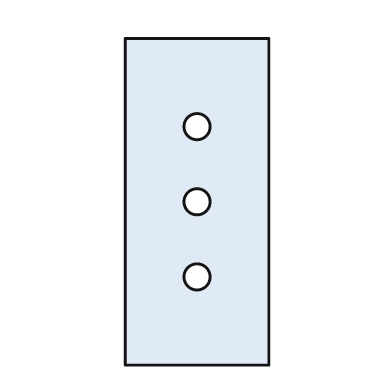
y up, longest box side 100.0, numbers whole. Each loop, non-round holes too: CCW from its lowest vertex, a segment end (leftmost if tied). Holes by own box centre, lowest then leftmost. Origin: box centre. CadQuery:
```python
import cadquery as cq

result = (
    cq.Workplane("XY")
    .moveTo(-22.0, -50.0)
    .lineTo(22.0, -50.0)
    .lineTo(22.0, 50.0)
    .lineTo(-22.0, 50.0)
    .close()
    .moveTo(0.0, -23.0)
    .circle(4.0)
    .moveTo(0.0, 0.0)
    .circle(4.0)
    .moveTo(0.0, 23.0)
    .circle(4.0)
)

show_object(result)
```